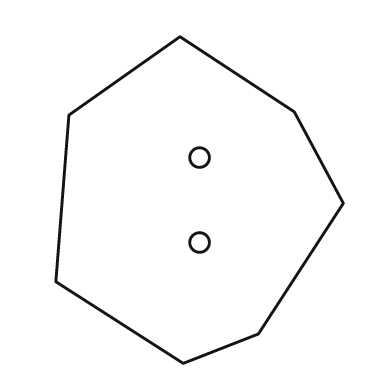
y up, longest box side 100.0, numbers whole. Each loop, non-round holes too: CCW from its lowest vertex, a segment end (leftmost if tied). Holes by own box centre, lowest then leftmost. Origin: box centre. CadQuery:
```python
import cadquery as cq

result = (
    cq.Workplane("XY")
    .moveTo(-5.0, -50.0)
    .lineTo(18.0, -41.0)
    .lineTo(44.0, -1.0)
    .lineTo(29.0, 27.0)
    .lineTo(-6.0, 50.0)
    .lineTo(-40.0, 26.0)
    .lineTo(-44.0, -25.0)
    .close()
    .moveTo(0.0, -13.0)
    .circle(3.0)
    .moveTo(0.0, 13.0)
    .circle(3.0)
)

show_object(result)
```